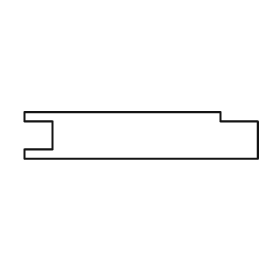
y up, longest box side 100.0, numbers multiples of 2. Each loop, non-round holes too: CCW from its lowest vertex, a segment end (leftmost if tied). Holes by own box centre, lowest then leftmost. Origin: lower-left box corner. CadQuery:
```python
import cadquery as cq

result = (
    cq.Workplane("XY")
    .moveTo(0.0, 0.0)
    .lineTo(100.0, 0.0)
    .lineTo(100.0, 16.0)
    .lineTo(84.0, 16.0)
    .lineTo(84.0, 20.0)
    .lineTo(0.0, 20.0)
    .lineTo(0.0, 16.0)
    .lineTo(12.0, 16.0)
    .lineTo(12.0, 4.0)
    .lineTo(0.0, 4.0)
    .close()
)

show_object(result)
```